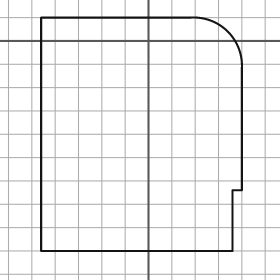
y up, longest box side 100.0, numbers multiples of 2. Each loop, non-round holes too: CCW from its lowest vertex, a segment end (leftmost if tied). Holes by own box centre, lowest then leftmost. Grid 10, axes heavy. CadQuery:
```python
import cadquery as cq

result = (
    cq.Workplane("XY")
    .moveTo(-46.0, -90.0)
    .lineTo(36.0, -90.0)
    .lineTo(36.0, -64.0)
    .lineTo(40.0, -64.0)
    .lineTo(40.0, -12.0)
    .threePointArc((34.0, 4.0), (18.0, 10.0))
    .lineTo(-46.0, 10.0)
    .close()
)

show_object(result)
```